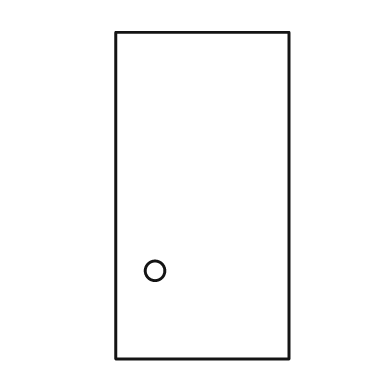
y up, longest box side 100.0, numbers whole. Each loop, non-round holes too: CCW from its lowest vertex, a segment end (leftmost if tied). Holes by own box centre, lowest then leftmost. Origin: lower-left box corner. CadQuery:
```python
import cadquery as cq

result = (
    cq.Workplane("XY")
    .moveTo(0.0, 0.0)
    .lineTo(53.0, 0.0)
    .lineTo(53.0, 100.0)
    .lineTo(0.0, 100.0)
    .close()
    .moveTo(12.0, 27.0)
    .circle(3.0)
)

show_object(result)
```